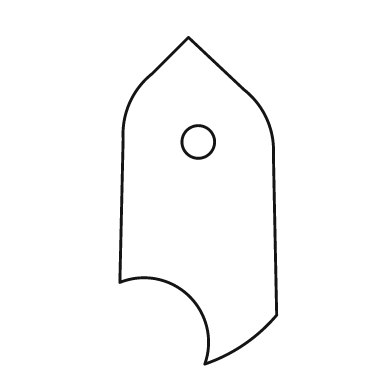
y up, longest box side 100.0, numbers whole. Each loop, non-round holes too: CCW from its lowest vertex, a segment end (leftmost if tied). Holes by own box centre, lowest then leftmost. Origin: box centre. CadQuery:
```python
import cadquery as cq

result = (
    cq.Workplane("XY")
    .moveTo(2.0, -50.0)
    .threePointArc((14.0, -44.0), (24.0, -35.0))
    .lineTo(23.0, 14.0)
    .threePointArc((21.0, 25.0), (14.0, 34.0))
    .lineTo(-3.0, 50.0)
    .lineTo(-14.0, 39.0)
    .threePointArc((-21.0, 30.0), (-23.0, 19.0))
    .lineTo(-24.0, -25.0)
    .threePointArc((-3.0, -29.0), (2.0, -50.0))
    .close()
    .moveTo(0.0, 18.0)
    .circle(5.0)
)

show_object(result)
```